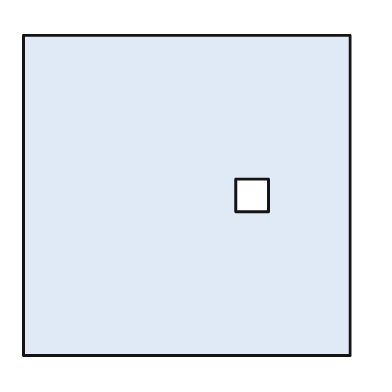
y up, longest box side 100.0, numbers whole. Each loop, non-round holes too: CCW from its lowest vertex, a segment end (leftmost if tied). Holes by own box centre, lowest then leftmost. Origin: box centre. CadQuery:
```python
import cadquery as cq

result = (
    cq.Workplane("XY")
    .moveTo(-50.0, -49.0)
    .lineTo(50.0, -49.0)
    .lineTo(50.0, 49.0)
    .lineTo(-50.0, 49.0)
    .close()
    .moveTo(15.0, -5.0)
    .lineTo(25.0, -5.0)
    .lineTo(25.0, 5.0)
    .lineTo(15.0, 5.0)
    .close()
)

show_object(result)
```